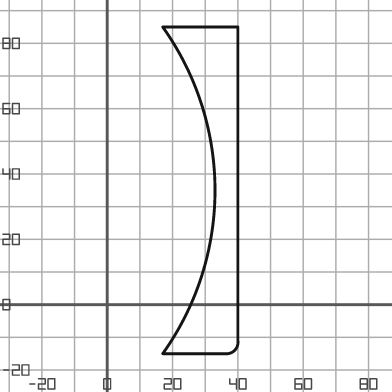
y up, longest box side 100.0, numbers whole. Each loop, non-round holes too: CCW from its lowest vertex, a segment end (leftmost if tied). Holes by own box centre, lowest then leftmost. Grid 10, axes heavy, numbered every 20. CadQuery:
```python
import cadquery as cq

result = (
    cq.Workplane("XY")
    .moveTo(17.0, -15.0)
    .lineTo(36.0, -15.0)
    .threePointArc((39.0, -14.0), (40.0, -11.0))
    .lineTo(40.0, 85.0)
    .lineTo(17.0, 85.0)
    .threePointArc((33.0, 35.0), (17.0, -15.0))
    .close()
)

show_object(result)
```